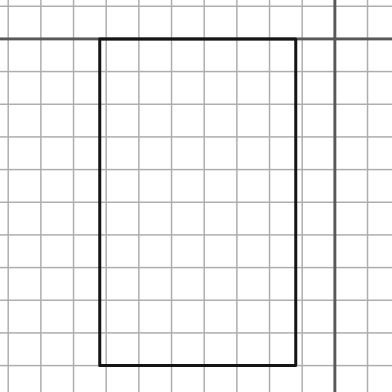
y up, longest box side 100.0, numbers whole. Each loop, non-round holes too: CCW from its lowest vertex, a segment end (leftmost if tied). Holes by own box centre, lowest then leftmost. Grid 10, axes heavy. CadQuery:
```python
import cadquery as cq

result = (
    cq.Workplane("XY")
    .moveTo(-72.0, -100.0)
    .lineTo(-12.0, -100.0)
    .lineTo(-12.0, 0.0)
    .lineTo(-72.0, 0.0)
    .close()
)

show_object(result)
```